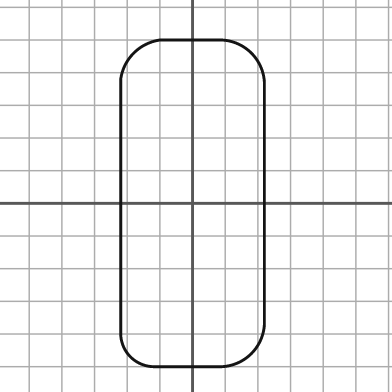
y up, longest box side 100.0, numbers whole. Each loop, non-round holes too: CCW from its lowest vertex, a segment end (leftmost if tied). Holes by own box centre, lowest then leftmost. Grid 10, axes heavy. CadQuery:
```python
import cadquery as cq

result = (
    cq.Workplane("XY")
    .moveTo(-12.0, -50.0)
    .lineTo(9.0, -50.0)
    .threePointArc((18.0, -46.0), (22.0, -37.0))
    .lineTo(22.0, 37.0)
    .threePointArc((18.0, 46.0), (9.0, 50.0))
    .lineTo(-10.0, 50.0)
    .threePointArc((-18.0, 46.0), (-22.0, 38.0))
    .lineTo(-22.0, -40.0)
    .threePointArc((-19.0, -47.0), (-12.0, -50.0))
    .close()
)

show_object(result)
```